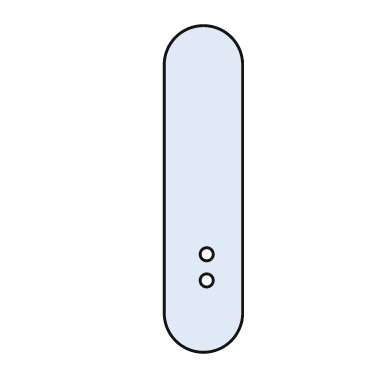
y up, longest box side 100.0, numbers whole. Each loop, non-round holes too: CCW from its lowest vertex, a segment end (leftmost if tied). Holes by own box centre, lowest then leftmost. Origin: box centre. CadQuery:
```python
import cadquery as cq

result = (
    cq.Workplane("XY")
    .moveTo(-12.0, -38.0)
    .threePointArc((0.0, -50.0), (12.0, -38.0))
    .lineTo(12.0, 38.0)
    .threePointArc((0.0, 50.0), (-12.0, 38.0))
    .close()
    .moveTo(1.0, -28.0)
    .circle(2.0)
    .moveTo(1.0, -20.0)
    .circle(2.0)
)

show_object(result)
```